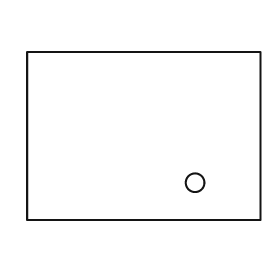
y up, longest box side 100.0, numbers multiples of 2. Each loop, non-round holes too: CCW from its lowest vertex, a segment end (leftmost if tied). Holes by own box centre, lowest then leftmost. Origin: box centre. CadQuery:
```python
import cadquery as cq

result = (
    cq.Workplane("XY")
    .moveTo(-50.0, -36.0)
    .lineTo(50.0, -36.0)
    .lineTo(50.0, 36.0)
    .lineTo(-50.0, 36.0)
    .close()
    .moveTo(22.0, -20.0)
    .circle(4.0)
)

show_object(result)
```